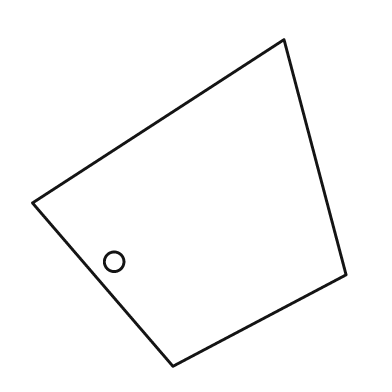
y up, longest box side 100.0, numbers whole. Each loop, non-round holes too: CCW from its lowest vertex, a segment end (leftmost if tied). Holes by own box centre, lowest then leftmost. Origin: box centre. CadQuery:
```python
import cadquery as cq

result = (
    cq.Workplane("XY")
    .moveTo(-5.0, -50.0)
    .lineTo(48.0, -22.0)
    .lineTo(29.0, 50.0)
    .lineTo(-48.0, 0.0)
    .close()
    .moveTo(-23.0, -18.0)
    .circle(3.0)
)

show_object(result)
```